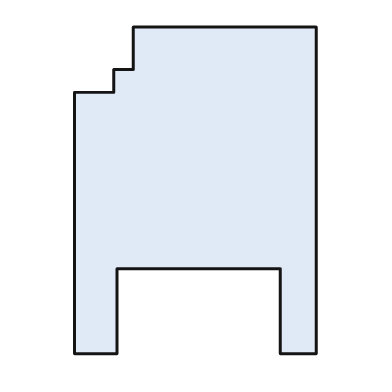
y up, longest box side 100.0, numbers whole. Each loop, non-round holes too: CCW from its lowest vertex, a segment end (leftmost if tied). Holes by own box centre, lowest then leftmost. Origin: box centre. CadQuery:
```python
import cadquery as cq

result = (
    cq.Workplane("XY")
    .moveTo(-37.0, -50.0)
    .lineTo(-24.0, -50.0)
    .lineTo(-24.0, -24.0)
    .lineTo(26.0, -24.0)
    .lineTo(26.0, -50.0)
    .lineTo(37.0, -50.0)
    .lineTo(37.0, 50.0)
    .lineTo(-19.0, 50.0)
    .lineTo(-19.0, 37.0)
    .lineTo(-25.0, 37.0)
    .lineTo(-25.0, 30.0)
    .lineTo(-37.0, 30.0)
    .close()
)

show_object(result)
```